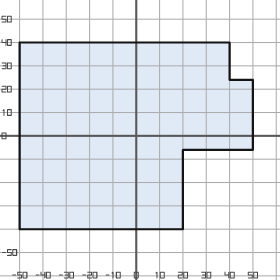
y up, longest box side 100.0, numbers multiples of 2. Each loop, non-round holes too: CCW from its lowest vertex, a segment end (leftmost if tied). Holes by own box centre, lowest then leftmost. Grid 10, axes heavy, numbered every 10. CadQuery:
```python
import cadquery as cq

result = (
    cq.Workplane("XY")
    .moveTo(-50.0, -40.0)
    .lineTo(20.0, -40.0)
    .lineTo(20.0, -6.0)
    .lineTo(50.0, -6.0)
    .lineTo(50.0, 24.0)
    .lineTo(40.0, 24.0)
    .lineTo(40.0, 40.0)
    .lineTo(-50.0, 40.0)
    .close()
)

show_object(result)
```